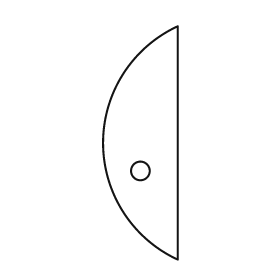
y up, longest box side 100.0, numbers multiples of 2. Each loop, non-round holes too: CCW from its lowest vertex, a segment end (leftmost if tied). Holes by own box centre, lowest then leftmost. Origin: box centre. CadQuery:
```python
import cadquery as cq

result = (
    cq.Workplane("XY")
    .moveTo(16.0, -50.0)
    .lineTo(16.0, 50.0)
    .threePointArc((-16.0, 0.0), (16.0, -50.0))
    .close()
    .moveTo(0.0, -12.0)
    .circle(4.0)
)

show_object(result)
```